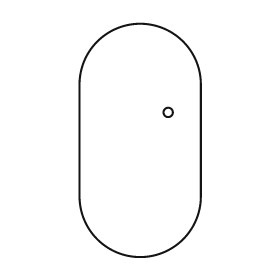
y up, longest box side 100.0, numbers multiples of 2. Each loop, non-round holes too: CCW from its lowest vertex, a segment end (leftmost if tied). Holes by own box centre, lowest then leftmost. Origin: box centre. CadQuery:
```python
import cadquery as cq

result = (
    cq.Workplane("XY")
    .moveTo(-26.0, -24.0)
    .threePointArc((0.0, -50.0), (26.0, -24.0))
    .lineTo(26.0, 24.0)
    .threePointArc((0.0, 50.0), (-26.0, 24.0))
    .close()
    .moveTo(12.0, 12.0)
    .circle(2.0)
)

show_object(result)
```